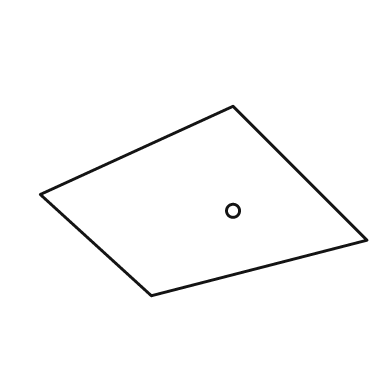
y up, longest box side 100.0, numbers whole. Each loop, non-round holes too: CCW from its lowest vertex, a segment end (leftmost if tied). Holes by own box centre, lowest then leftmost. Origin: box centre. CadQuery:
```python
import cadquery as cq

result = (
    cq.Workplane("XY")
    .moveTo(-16.0, -29.0)
    .lineTo(50.0, -12.0)
    .lineTo(9.0, 29.0)
    .lineTo(-50.0, 2.0)
    .close()
    .moveTo(9.0, -3.0)
    .circle(2.0)
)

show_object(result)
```